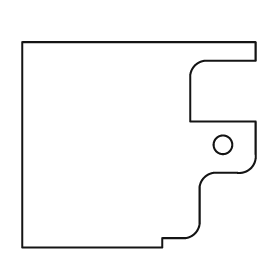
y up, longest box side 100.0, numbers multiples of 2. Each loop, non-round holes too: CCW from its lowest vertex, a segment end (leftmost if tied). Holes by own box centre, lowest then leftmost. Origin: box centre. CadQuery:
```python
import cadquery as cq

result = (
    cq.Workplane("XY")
    .moveTo(-50.0, -44.0)
    .lineTo(10.0, -44.0)
    .lineTo(10.0, -40.0)
    .lineTo(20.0, -40.0)
    .threePointArc((24.0, -38.0), (26.0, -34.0))
    .lineTo(26.0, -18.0)
    .threePointArc((28.0, -14.0), (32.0, -12.0))
    .lineTo(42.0, -12.0)
    .threePointArc((48.0, -10.0), (50.0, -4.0))
    .lineTo(50.0, 10.0)
    .lineTo(22.0, 10.0)
    .lineTo(22.0, 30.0)
    .threePointArc((24.0, 34.0), (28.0, 36.0))
    .lineTo(50.0, 36.0)
    .lineTo(50.0, 44.0)
    .lineTo(-50.0, 44.0)
    .close()
    .moveTo(36.0, 0.0)
    .circle(4.0)
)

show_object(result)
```